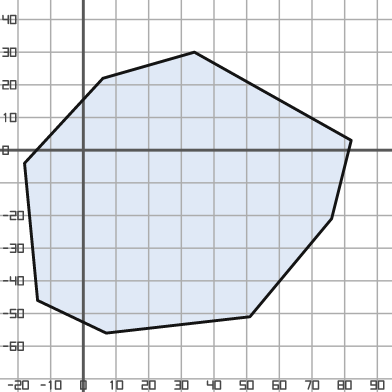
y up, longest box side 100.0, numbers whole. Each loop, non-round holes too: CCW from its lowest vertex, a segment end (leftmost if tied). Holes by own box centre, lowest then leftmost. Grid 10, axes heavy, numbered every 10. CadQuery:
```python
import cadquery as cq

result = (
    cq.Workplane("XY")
    .moveTo(7.0, -56.0)
    .lineTo(51.0, -51.0)
    .lineTo(76.0, -21.0)
    .lineTo(82.0, 3.0)
    .lineTo(34.0, 30.0)
    .lineTo(6.0, 22.0)
    .lineTo(-18.0, -4.0)
    .lineTo(-14.0, -46.0)
    .close()
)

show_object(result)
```